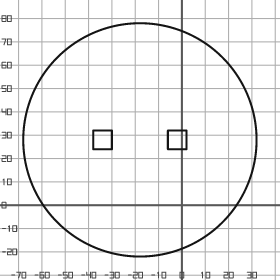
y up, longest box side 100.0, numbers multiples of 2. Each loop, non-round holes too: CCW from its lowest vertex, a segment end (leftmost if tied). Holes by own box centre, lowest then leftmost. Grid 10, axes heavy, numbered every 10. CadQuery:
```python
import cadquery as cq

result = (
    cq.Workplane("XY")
    .moveTo(-18.0, 28.0)
    .circle(50.0)
    .moveTo(-38.0, 24.0)
    .lineTo(-30.0, 24.0)
    .lineTo(-30.0, 32.0)
    .lineTo(-38.0, 32.0)
    .close()
    .moveTo(-6.0, 24.0)
    .lineTo(2.0, 24.0)
    .lineTo(2.0, 32.0)
    .lineTo(-6.0, 32.0)
    .close()
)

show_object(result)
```